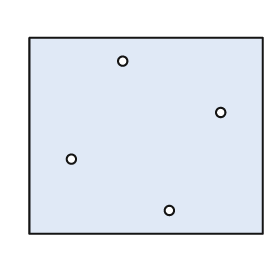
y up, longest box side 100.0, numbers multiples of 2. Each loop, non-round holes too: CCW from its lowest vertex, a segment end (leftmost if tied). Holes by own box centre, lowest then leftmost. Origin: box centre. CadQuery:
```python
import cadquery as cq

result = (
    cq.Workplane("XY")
    .moveTo(-50.0, -42.0)
    .lineTo(50.0, -42.0)
    .lineTo(50.0, 42.0)
    .lineTo(-50.0, 42.0)
    .close()
    .moveTo(10.0, -32.0)
    .circle(2.0)
    .moveTo(-32.0, -10.0)
    .circle(2.0)
    .moveTo(32.0, 10.0)
    .circle(2.0)
    .moveTo(-10.0, 32.0)
    .circle(2.0)
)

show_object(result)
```